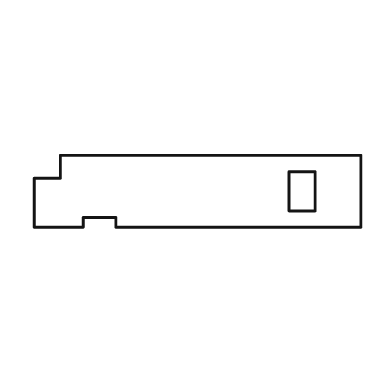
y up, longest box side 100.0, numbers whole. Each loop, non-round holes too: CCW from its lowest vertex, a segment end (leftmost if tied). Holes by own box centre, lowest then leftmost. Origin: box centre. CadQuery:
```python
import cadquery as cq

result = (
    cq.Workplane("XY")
    .moveTo(-50.0, -11.0)
    .lineTo(-35.0, -11.0)
    .lineTo(-35.0, -8.0)
    .lineTo(-25.0, -8.0)
    .lineTo(-25.0, -11.0)
    .lineTo(50.0, -11.0)
    .lineTo(50.0, 11.0)
    .lineTo(-42.0, 11.0)
    .lineTo(-42.0, 4.0)
    .lineTo(-50.0, 4.0)
    .close()
    .moveTo(28.0, -6.0)
    .lineTo(36.0, -6.0)
    .lineTo(36.0, 6.0)
    .lineTo(28.0, 6.0)
    .close()
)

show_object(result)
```